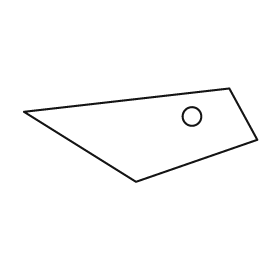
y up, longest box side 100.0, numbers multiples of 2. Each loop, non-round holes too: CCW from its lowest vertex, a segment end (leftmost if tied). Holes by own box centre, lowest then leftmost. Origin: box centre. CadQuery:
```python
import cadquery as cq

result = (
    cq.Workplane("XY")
    .moveTo(-2.0, -20.0)
    .lineTo(50.0, -2.0)
    .lineTo(38.0, 20.0)
    .lineTo(-50.0, 10.0)
    .close()
    .moveTo(22.0, 8.0)
    .circle(4.0)
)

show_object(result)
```